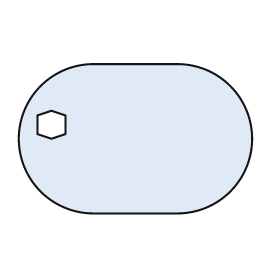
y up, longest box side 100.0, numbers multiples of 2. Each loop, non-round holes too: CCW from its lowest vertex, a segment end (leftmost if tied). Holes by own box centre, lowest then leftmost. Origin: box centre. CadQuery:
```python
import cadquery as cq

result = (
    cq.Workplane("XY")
    .moveTo(-18.0, -32.0)
    .lineTo(18.0, -32.0)
    .threePointArc((50.0, 0.0), (18.0, 32.0))
    .lineTo(-18.0, 32.0)
    .threePointArc((-50.0, 0.0), (-18.0, -32.0))
    .close()
    .moveTo(-36.0, 0.0)
    .lineTo(-30.0, 2.0)
    .lineTo(-30.0, 10.0)
    .lineTo(-36.0, 12.0)
    .lineTo(-42.0, 10.0)
    .lineTo(-42.0, 2.0)
    .close()
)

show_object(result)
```